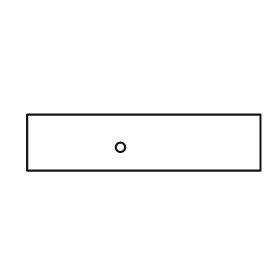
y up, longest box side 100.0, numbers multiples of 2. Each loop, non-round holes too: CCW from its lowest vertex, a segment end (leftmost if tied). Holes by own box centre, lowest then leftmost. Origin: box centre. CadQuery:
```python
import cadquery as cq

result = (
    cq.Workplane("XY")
    .moveTo(-50.0, -12.0)
    .lineTo(50.0, -12.0)
    .lineTo(50.0, 12.0)
    .lineTo(-50.0, 12.0)
    .close()
    .moveTo(-10.0, -2.0)
    .circle(2.0)
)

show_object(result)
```